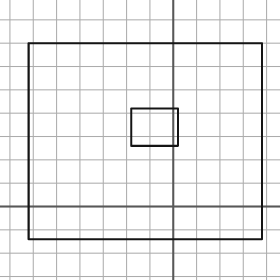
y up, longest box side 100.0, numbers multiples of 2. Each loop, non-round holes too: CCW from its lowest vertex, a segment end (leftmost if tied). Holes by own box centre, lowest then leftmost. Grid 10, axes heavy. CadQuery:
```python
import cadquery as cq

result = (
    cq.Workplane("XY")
    .moveTo(-62.0, -14.0)
    .lineTo(38.0, -14.0)
    .lineTo(38.0, 70.0)
    .lineTo(-62.0, 70.0)
    .close()
    .moveTo(-18.0, 26.0)
    .lineTo(2.0, 26.0)
    .lineTo(2.0, 42.0)
    .lineTo(-18.0, 42.0)
    .close()
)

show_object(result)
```